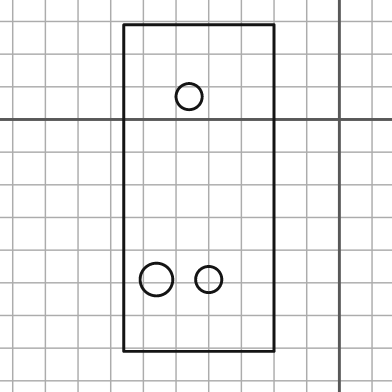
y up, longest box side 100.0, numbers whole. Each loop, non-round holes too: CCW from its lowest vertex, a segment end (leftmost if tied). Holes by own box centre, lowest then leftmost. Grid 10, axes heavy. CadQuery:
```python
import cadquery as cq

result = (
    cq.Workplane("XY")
    .moveTo(-66.0, -71.0)
    .lineTo(-20.0, -71.0)
    .lineTo(-20.0, 29.0)
    .lineTo(-66.0, 29.0)
    .close()
    .moveTo(-56.0, -49.0)
    .circle(5.0)
    .moveTo(-40.0, -49.0)
    .circle(4.0)
    .moveTo(-46.0, 7.0)
    .circle(4.0)
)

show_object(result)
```